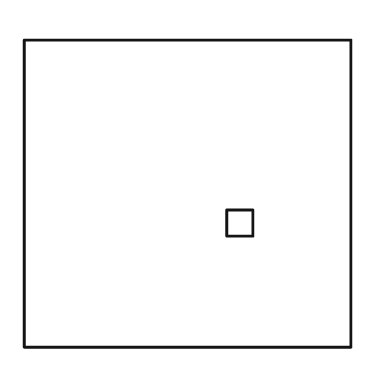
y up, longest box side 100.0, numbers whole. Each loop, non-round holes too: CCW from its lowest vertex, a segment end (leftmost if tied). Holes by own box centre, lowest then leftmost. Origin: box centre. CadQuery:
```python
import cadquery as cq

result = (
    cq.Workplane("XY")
    .moveTo(-50.0, -47.0)
    .lineTo(50.0, -47.0)
    .lineTo(50.0, 47.0)
    .lineTo(-50.0, 47.0)
    .close()
    .moveTo(12.0, -13.0)
    .lineTo(20.0, -13.0)
    .lineTo(20.0, -5.0)
    .lineTo(12.0, -5.0)
    .close()
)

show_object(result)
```